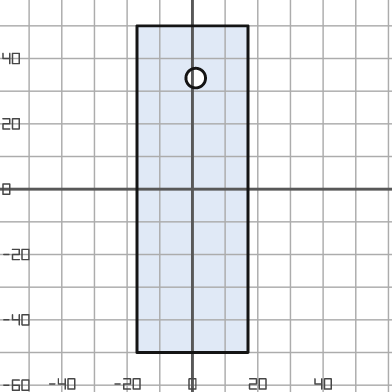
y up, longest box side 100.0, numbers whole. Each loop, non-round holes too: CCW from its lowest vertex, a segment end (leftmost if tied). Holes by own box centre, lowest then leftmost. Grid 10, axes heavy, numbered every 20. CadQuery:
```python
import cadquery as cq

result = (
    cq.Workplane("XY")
    .moveTo(-17.0, -50.0)
    .lineTo(17.0, -50.0)
    .lineTo(17.0, 50.0)
    .lineTo(-17.0, 50.0)
    .close()
    .moveTo(1.0, 34.0)
    .circle(3.0)
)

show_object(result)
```